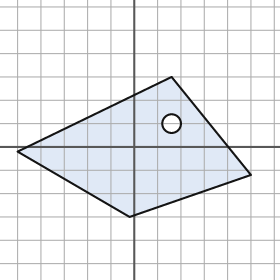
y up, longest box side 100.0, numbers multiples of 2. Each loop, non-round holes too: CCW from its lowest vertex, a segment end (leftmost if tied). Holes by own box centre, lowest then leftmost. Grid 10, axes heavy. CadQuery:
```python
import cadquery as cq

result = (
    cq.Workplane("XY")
    .moveTo(-2.0, -30.0)
    .lineTo(50.0, -12.0)
    .lineTo(16.0, 30.0)
    .lineTo(-50.0, -2.0)
    .close()
    .moveTo(16.0, 10.0)
    .circle(4.0)
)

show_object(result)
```